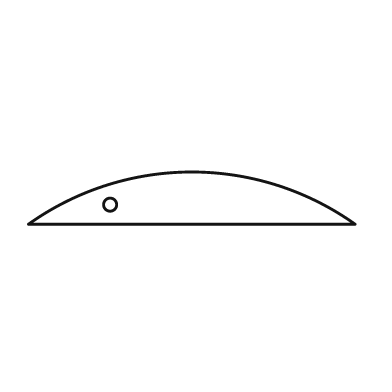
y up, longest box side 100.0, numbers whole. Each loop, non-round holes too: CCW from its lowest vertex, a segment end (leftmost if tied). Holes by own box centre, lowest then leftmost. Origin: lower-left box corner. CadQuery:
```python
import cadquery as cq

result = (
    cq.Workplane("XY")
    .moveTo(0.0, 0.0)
    .lineTo(100.0, 0.0)
    .threePointArc((50.0, 16.0), (0.0, 0.0))
    .close()
    .moveTo(25.0, 6.0)
    .circle(2.0)
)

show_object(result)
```